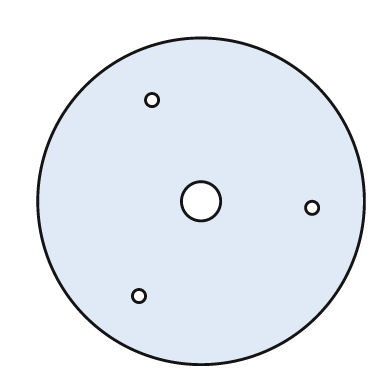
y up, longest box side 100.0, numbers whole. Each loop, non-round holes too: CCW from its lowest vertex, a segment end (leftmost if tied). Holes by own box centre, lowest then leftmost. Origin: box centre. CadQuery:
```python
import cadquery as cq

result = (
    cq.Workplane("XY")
    .moveTo(0.0, 0.0)
    .circle(50.0)
    .moveTo(-19.0, -29.0)
    .circle(2.0)
    .moveTo(34.0, -2.0)
    .circle(2.0)
    .moveTo(0.0, 0.0)
    .circle(6.0)
    .moveTo(-15.0, 31.0)
    .circle(2.0)
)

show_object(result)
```